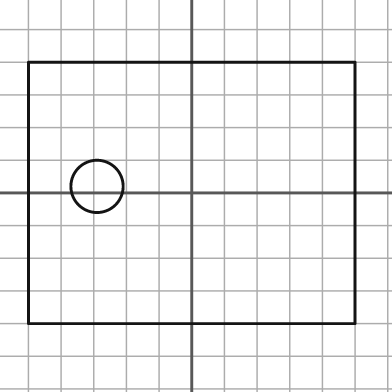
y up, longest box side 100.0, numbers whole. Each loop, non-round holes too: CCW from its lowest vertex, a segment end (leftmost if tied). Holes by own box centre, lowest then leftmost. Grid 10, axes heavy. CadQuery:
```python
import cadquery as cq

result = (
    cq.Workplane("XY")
    .moveTo(-50.0, -40.0)
    .lineTo(50.0, -40.0)
    .lineTo(50.0, 40.0)
    .lineTo(-50.0, 40.0)
    .close()
    .moveTo(-29.0, 2.0)
    .circle(8.0)
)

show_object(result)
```